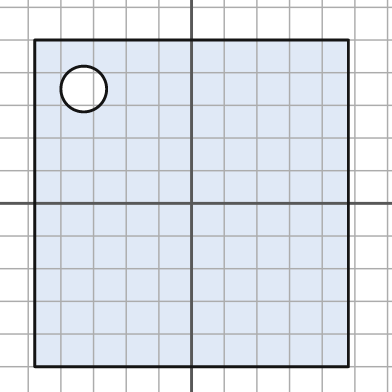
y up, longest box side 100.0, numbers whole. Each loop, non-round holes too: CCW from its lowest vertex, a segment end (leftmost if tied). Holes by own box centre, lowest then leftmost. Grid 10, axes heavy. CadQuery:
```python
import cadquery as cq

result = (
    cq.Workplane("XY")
    .moveTo(-48.0, -50.0)
    .lineTo(48.0, -50.0)
    .lineTo(48.0, 50.0)
    .lineTo(-48.0, 50.0)
    .close()
    .moveTo(-33.0, 35.0)
    .circle(7.0)
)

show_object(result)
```